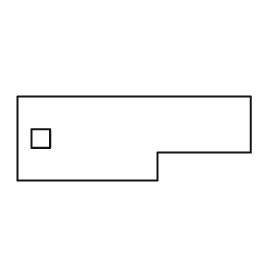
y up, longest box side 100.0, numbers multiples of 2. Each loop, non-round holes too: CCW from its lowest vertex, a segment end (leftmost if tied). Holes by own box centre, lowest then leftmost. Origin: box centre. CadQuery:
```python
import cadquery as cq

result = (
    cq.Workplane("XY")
    .moveTo(-50.0, -18.0)
    .lineTo(10.0, -18.0)
    .lineTo(10.0, -6.0)
    .lineTo(50.0, -6.0)
    .lineTo(50.0, 18.0)
    .lineTo(-50.0, 18.0)
    .close()
    .moveTo(-44.0, -4.0)
    .lineTo(-36.0, -4.0)
    .lineTo(-36.0, 4.0)
    .lineTo(-44.0, 4.0)
    .close()
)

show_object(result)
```